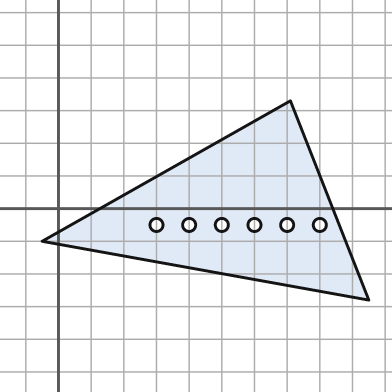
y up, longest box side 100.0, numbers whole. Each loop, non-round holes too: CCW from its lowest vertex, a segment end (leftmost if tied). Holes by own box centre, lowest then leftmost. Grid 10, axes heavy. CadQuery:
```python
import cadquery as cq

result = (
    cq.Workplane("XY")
    .moveTo(95.0, -28.0)
    .lineTo(71.0, 33.0)
    .lineTo(-5.0, -10.0)
    .close()
    .moveTo(30.0, -5.0)
    .circle(2.0)
    .moveTo(40.0, -5.0)
    .circle(2.0)
    .moveTo(50.0, -5.0)
    .circle(2.0)
    .moveTo(60.0, -5.0)
    .circle(2.0)
    .moveTo(70.0, -5.0)
    .circle(2.0)
    .moveTo(80.0, -5.0)
    .circle(2.0)
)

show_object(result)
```